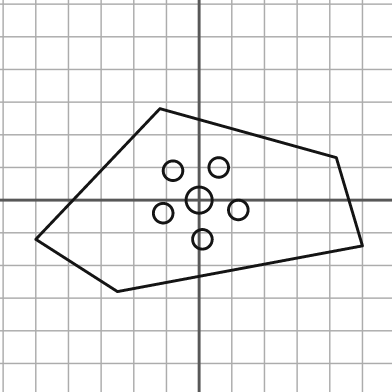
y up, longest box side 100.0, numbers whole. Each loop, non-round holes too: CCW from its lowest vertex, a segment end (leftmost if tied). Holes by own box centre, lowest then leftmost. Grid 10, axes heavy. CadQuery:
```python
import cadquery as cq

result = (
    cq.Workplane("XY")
    .moveTo(-25.0, -28.0)
    .lineTo(50.0, -14.0)
    .lineTo(42.0, 13.0)
    .lineTo(-12.0, 28.0)
    .lineTo(-50.0, -12.0)
    .close()
    .moveTo(1.0, -12.0)
    .circle(3.0)
    .moveTo(-11.0, -4.0)
    .circle(3.0)
    .moveTo(12.0, -3.0)
    .circle(3.0)
    .moveTo(0.0, 0.0)
    .circle(4.0)
    .moveTo(-8.0, 9.0)
    .circle(3.0)
    .moveTo(6.0, 10.0)
    .circle(3.0)
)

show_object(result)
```